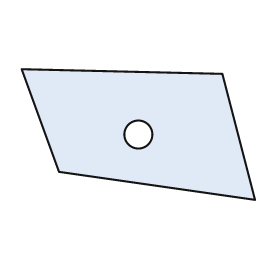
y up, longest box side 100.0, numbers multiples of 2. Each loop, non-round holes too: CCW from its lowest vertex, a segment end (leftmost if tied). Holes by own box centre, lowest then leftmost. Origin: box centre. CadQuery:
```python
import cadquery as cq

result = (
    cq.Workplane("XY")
    .moveTo(50.0, -28.0)
    .lineTo(36.0, 26.0)
    .lineTo(-50.0, 28.0)
    .lineTo(-34.0, -16.0)
    .close()
    .moveTo(0.0, 0.0)
    .circle(6.0)
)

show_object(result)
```